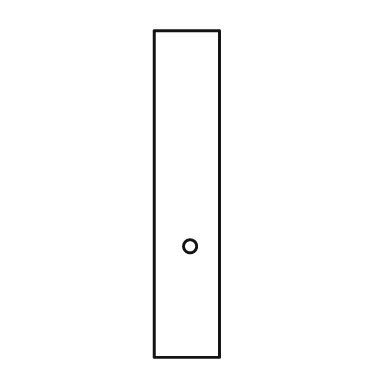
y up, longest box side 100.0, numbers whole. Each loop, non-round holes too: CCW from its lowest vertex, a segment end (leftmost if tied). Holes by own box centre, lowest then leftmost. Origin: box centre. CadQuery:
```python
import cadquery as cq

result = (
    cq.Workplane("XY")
    .moveTo(-10.0, -50.0)
    .lineTo(10.0, -50.0)
    .lineTo(10.0, 50.0)
    .lineTo(-10.0, 50.0)
    .close()
    .moveTo(1.0, -16.0)
    .circle(2.0)
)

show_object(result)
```